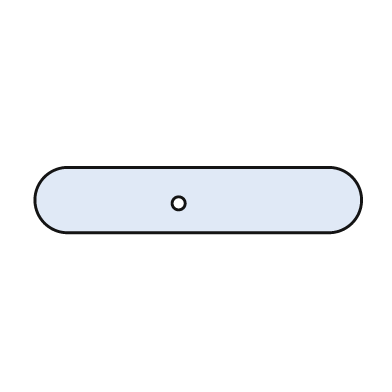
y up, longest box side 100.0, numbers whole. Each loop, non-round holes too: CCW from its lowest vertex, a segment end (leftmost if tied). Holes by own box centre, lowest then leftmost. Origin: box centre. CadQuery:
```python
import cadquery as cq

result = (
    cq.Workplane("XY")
    .moveTo(-40.0, -10.0)
    .lineTo(40.0, -10.0)
    .threePointArc((50.0, 0.0), (40.0, 10.0))
    .lineTo(-40.0, 10.0)
    .threePointArc((-50.0, 0.0), (-40.0, -10.0))
    .close()
    .moveTo(-6.0, -1.0)
    .circle(2.0)
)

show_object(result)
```